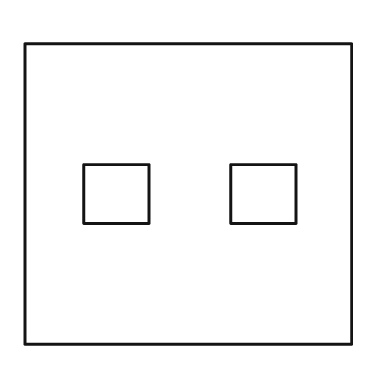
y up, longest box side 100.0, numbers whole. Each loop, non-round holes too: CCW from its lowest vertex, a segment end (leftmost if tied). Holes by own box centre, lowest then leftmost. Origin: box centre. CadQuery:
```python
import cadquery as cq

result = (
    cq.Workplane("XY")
    .moveTo(-50.0, -46.0)
    .lineTo(50.0, -46.0)
    .lineTo(50.0, 46.0)
    .lineTo(-50.0, 46.0)
    .close()
    .moveTo(-32.0, -9.0)
    .lineTo(-12.0, -9.0)
    .lineTo(-12.0, 9.0)
    .lineTo(-32.0, 9.0)
    .close()
    .moveTo(13.0, -9.0)
    .lineTo(33.0, -9.0)
    .lineTo(33.0, 9.0)
    .lineTo(13.0, 9.0)
    .close()
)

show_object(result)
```